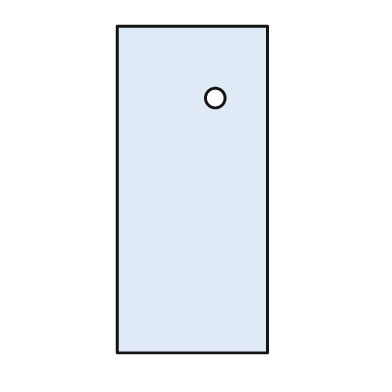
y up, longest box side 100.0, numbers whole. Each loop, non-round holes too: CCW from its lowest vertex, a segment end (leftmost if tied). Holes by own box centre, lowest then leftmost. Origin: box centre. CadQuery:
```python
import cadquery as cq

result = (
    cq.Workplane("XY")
    .moveTo(-23.0, -50.0)
    .lineTo(23.0, -50.0)
    .lineTo(23.0, 50.0)
    .lineTo(-23.0, 50.0)
    .close()
    .moveTo(7.0, 28.0)
    .circle(3.0)
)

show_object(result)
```